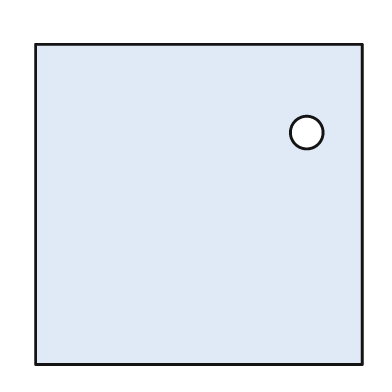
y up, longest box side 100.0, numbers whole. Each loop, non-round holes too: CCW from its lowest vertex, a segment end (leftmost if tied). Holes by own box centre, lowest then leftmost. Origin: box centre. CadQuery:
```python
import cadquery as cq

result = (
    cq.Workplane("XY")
    .moveTo(-50.0, -49.0)
    .lineTo(50.0, -49.0)
    .lineTo(50.0, 49.0)
    .lineTo(-50.0, 49.0)
    .close()
    .moveTo(33.0, 22.0)
    .circle(5.0)
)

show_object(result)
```